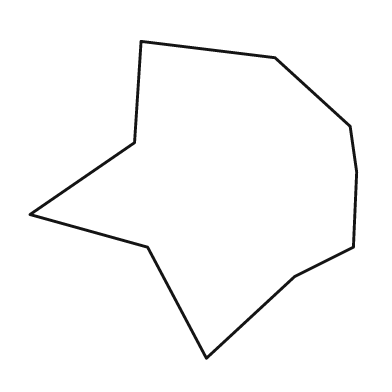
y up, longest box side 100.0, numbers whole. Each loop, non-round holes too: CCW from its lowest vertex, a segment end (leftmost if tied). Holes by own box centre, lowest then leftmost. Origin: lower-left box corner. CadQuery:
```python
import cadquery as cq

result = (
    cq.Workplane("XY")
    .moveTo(54.0, 0.0)
    .lineTo(81.0, 25.0)
    .lineTo(99.0, 34.0)
    .lineTo(100.0, 57.0)
    .lineTo(98.0, 71.0)
    .lineTo(75.0, 92.0)
    .lineTo(34.0, 97.0)
    .lineTo(32.0, 66.0)
    .lineTo(0.0, 44.0)
    .lineTo(36.0, 34.0)
    .close()
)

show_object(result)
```